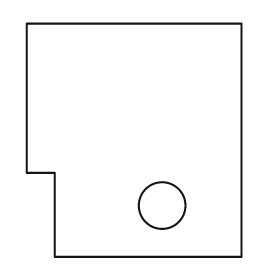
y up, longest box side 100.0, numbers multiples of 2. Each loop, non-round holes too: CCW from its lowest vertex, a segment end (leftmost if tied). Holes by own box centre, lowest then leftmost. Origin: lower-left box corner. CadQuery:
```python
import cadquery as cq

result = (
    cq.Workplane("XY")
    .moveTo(12.0, 0.0)
    .lineTo(92.0, 0.0)
    .lineTo(92.0, 100.0)
    .lineTo(0.0, 100.0)
    .lineTo(0.0, 36.0)
    .lineTo(12.0, 36.0)
    .close()
    .moveTo(58.0, 22.0)
    .circle(10.0)
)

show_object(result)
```